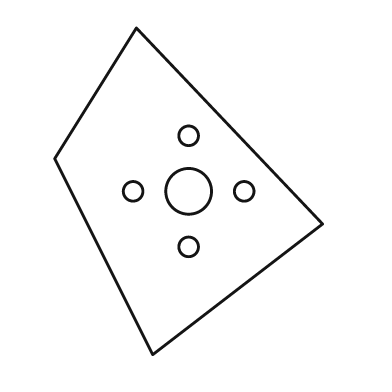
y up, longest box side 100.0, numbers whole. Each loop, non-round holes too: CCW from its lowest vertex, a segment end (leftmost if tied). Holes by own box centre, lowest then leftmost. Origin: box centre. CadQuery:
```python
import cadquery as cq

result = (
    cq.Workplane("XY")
    .moveTo(-11.0, -50.0)
    .lineTo(41.0, -10.0)
    .lineTo(-16.0, 50.0)
    .lineTo(-41.0, 10.0)
    .close()
    .moveTo(0.0, -17.0)
    .circle(3.0)
    .moveTo(-17.0, 0.0)
    .circle(3.0)
    .moveTo(0.0, 0.0)
    .circle(7.0)
    .moveTo(17.0, 0.0)
    .circle(3.0)
    .moveTo(0.0, 17.0)
    .circle(3.0)
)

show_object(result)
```